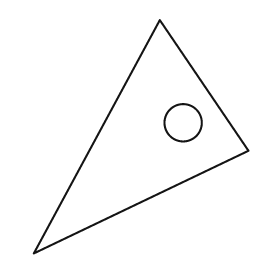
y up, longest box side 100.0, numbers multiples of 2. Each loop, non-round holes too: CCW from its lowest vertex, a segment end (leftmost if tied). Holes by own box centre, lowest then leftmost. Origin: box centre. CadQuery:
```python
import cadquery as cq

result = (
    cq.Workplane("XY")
    .moveTo(-46.0, -50.0)
    .lineTo(46.0, -6.0)
    .lineTo(8.0, 50.0)
    .close()
    .moveTo(18.0, 6.0)
    .circle(8.0)
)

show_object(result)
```